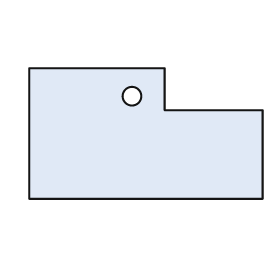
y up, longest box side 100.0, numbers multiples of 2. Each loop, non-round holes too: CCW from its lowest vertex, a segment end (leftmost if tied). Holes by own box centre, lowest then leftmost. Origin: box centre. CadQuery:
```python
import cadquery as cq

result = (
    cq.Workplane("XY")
    .moveTo(-50.0, -28.0)
    .lineTo(50.0, -28.0)
    .lineTo(50.0, 10.0)
    .lineTo(8.0, 10.0)
    .lineTo(8.0, 28.0)
    .lineTo(-50.0, 28.0)
    .close()
    .moveTo(-6.0, 16.0)
    .circle(4.0)
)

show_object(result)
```